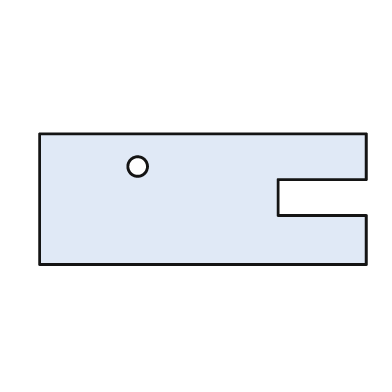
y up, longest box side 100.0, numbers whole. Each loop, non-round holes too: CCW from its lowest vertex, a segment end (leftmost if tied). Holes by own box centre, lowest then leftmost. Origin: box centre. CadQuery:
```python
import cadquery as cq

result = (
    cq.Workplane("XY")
    .moveTo(-50.0, -20.0)
    .lineTo(50.0, -20.0)
    .lineTo(50.0, -5.0)
    .lineTo(23.0, -5.0)
    .lineTo(23.0, 6.0)
    .lineTo(50.0, 6.0)
    .lineTo(50.0, 20.0)
    .lineTo(-50.0, 20.0)
    .close()
    .moveTo(-20.0, 10.0)
    .circle(3.0)
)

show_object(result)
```